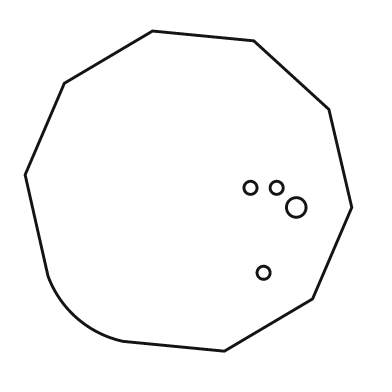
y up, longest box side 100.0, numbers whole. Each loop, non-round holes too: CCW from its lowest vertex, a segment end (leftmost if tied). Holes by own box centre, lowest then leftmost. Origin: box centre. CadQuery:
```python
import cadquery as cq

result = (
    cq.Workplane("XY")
    .moveTo(11.0, -49.0)
    .lineTo(38.0, -33.0)
    .lineTo(50.0, -5.0)
    .lineTo(43.0, 25.0)
    .lineTo(20.0, 46.0)
    .lineTo(-11.0, 49.0)
    .lineTo(-38.0, 33.0)
    .lineTo(-50.0, 5.0)
    .lineTo(-43.0, -26.0)
    .threePointArc((-34.0, -39.0), (-20.0, -46.0))
    .close()
    .moveTo(23.0, -25.0)
    .circle(2.0)
    .moveTo(33.0, -5.0)
    .circle(3.0)
    .moveTo(19.0, 1.0)
    .circle(2.0)
    .moveTo(27.0, 1.0)
    .circle(2.0)
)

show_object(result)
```